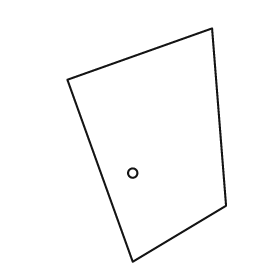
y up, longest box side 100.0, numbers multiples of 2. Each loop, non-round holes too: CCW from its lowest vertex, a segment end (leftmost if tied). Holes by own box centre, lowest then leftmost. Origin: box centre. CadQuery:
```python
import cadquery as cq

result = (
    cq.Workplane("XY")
    .moveTo(-6.0, -50.0)
    .lineTo(34.0, -26.0)
    .lineTo(28.0, 50.0)
    .lineTo(-34.0, 28.0)
    .close()
    .moveTo(-6.0, -12.0)
    .circle(2.0)
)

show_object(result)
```